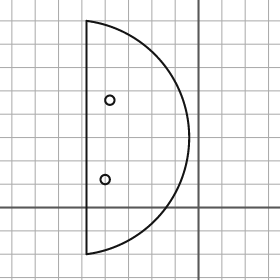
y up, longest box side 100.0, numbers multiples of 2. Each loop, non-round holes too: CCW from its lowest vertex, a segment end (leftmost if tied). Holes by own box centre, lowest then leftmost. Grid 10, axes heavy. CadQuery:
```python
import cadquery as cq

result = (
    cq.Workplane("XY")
    .moveTo(-48.0, -20.0)
    .threePointArc((-4.0, 30.0), (-48.0, 80.0))
    .close()
    .moveTo(-40.0, 12.0)
    .circle(2.0)
    .moveTo(-38.0, 46.0)
    .circle(2.0)
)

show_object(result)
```